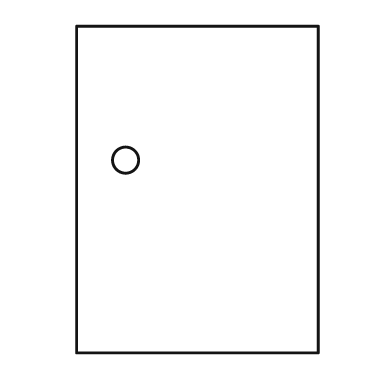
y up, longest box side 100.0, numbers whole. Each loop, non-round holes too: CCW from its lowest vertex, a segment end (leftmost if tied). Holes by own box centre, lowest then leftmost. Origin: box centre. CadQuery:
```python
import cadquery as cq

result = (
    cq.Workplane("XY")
    .moveTo(-37.0, -50.0)
    .lineTo(37.0, -50.0)
    .lineTo(37.0, 50.0)
    .lineTo(-37.0, 50.0)
    .close()
    .moveTo(-22.0, 9.0)
    .circle(4.0)
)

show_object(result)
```